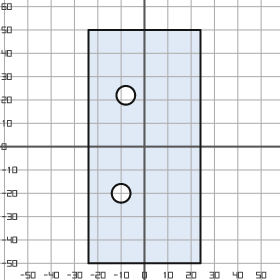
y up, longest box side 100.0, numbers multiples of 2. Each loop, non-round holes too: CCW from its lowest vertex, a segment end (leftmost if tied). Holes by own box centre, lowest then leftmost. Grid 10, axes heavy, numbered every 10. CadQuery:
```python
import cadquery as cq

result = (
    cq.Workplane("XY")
    .moveTo(-24.0, -50.0)
    .lineTo(24.0, -50.0)
    .lineTo(24.0, 50.0)
    .lineTo(-24.0, 50.0)
    .close()
    .moveTo(-10.0, -20.0)
    .circle(4.0)
    .moveTo(-8.0, 22.0)
    .circle(4.0)
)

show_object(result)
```